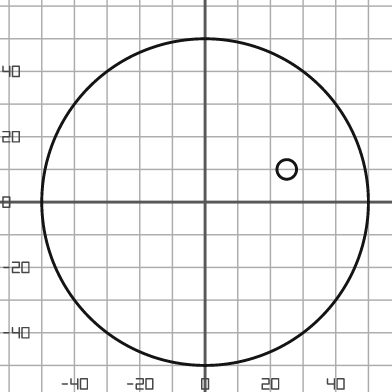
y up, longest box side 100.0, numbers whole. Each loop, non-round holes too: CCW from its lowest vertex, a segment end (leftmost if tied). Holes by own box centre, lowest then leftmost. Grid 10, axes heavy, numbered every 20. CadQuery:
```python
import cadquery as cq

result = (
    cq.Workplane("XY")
    .moveTo(0.0, 0.0)
    .circle(50.0)
    .moveTo(25.0, 10.0)
    .circle(3.0)
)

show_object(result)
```